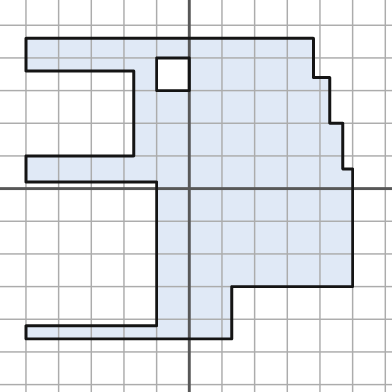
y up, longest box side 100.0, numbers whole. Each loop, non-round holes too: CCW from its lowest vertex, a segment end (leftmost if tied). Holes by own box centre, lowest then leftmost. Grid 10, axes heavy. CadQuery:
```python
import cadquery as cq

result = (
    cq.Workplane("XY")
    .moveTo(-50.0, -46.0)
    .lineTo(13.0, -46.0)
    .lineTo(13.0, -30.0)
    .lineTo(50.0, -30.0)
    .lineTo(50.0, 6.0)
    .lineTo(47.0, 6.0)
    .lineTo(47.0, 20.0)
    .lineTo(43.0, 20.0)
    .lineTo(43.0, 34.0)
    .lineTo(38.0, 34.0)
    .lineTo(38.0, 46.0)
    .lineTo(-50.0, 46.0)
    .lineTo(-50.0, 36.0)
    .lineTo(-17.0, 36.0)
    .lineTo(-17.0, 10.0)
    .lineTo(-50.0, 10.0)
    .lineTo(-50.0, 2.0)
    .lineTo(-10.0, 2.0)
    .lineTo(-10.0, -42.0)
    .lineTo(-50.0, -42.0)
    .close()
    .moveTo(-10.0, 30.0)
    .lineTo(0.0, 30.0)
    .lineTo(0.0, 40.0)
    .lineTo(-10.0, 40.0)
    .close()
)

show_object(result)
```